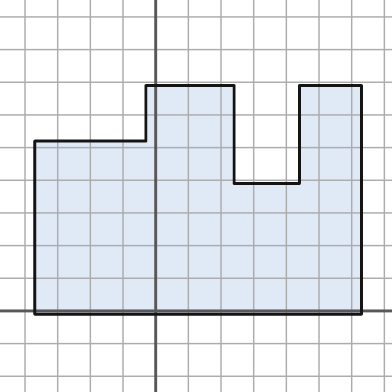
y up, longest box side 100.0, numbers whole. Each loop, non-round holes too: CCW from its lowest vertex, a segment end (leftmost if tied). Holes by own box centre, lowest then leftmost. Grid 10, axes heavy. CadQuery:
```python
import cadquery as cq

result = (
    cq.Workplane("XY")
    .moveTo(-37.0, -1.0)
    .lineTo(63.0, -1.0)
    .lineTo(63.0, 69.0)
    .lineTo(44.0, 69.0)
    .lineTo(44.0, 39.0)
    .lineTo(24.0, 39.0)
    .lineTo(24.0, 69.0)
    .lineTo(-3.0, 69.0)
    .lineTo(-3.0, 52.0)
    .lineTo(-37.0, 52.0)
    .close()
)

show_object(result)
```